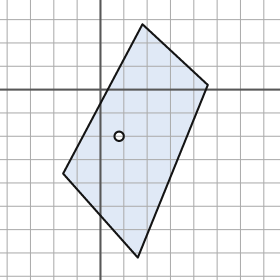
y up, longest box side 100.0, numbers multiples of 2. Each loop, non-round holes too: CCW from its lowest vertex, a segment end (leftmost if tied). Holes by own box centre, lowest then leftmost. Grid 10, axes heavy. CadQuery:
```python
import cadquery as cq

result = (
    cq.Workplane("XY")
    .moveTo(16.0, -72.0)
    .lineTo(46.0, 2.0)
    .lineTo(18.0, 28.0)
    .lineTo(-16.0, -36.0)
    .close()
    .moveTo(8.0, -20.0)
    .circle(2.0)
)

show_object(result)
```